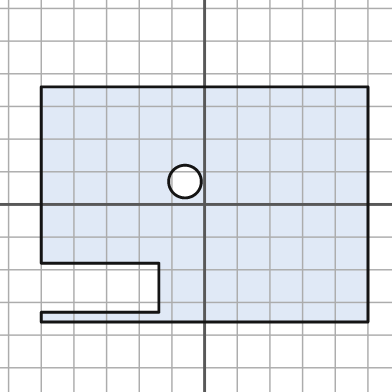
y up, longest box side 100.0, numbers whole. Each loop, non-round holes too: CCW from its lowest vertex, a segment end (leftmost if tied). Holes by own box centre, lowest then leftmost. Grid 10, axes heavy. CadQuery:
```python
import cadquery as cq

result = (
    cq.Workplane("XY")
    .moveTo(-50.0, -36.0)
    .lineTo(50.0, -36.0)
    .lineTo(50.0, 36.0)
    .lineTo(-50.0, 36.0)
    .lineTo(-50.0, -18.0)
    .lineTo(-14.0, -18.0)
    .lineTo(-14.0, -33.0)
    .lineTo(-50.0, -33.0)
    .close()
    .moveTo(-6.0, 7.0)
    .circle(5.0)
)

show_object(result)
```